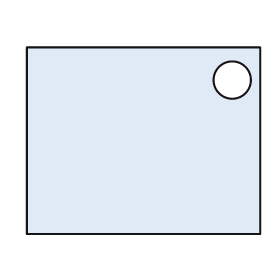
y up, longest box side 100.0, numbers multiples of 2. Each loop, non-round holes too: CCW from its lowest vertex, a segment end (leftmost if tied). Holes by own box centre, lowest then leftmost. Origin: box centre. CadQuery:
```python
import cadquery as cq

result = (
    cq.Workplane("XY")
    .moveTo(-50.0, -40.0)
    .lineTo(50.0, -40.0)
    .lineTo(50.0, 40.0)
    .lineTo(-50.0, 40.0)
    .close()
    .moveTo(38.0, 26.0)
    .circle(8.0)
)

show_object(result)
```